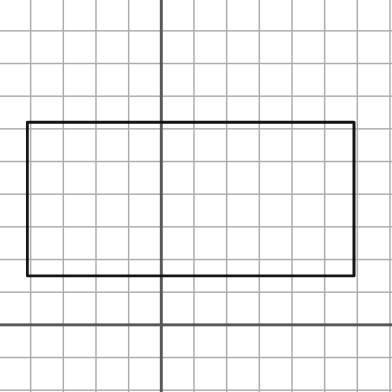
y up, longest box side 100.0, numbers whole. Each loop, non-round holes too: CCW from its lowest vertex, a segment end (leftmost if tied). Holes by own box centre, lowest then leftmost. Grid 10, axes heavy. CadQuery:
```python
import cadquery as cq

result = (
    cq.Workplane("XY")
    .moveTo(-41.0, 15.0)
    .lineTo(59.0, 15.0)
    .lineTo(59.0, 62.0)
    .lineTo(-41.0, 62.0)
    .close()
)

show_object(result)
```